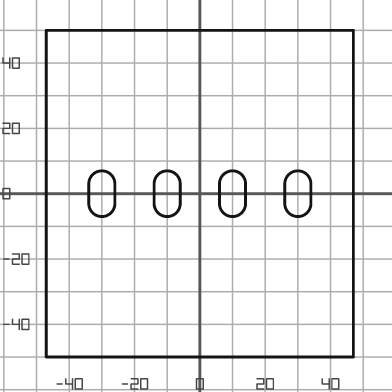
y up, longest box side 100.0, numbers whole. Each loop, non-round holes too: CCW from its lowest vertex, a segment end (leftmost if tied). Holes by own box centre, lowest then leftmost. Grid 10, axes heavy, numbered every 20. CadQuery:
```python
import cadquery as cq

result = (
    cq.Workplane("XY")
    .moveTo(-47.0, -50.0)
    .lineTo(47.0, -50.0)
    .lineTo(47.0, 50.0)
    .lineTo(-47.0, 50.0)
    .close()
    .moveTo(-34.0, -3.0)
    .threePointArc((-30.0, -7.0), (-26.0, -3.0))
    .lineTo(-26.0, 3.0)
    .threePointArc((-30.0, 7.0), (-34.0, 3.0))
    .close()
    .moveTo(-14.0, -3.0)
    .threePointArc((-10.0, -7.0), (-6.0, -3.0))
    .lineTo(-6.0, 3.0)
    .threePointArc((-10.0, 7.0), (-14.0, 3.0))
    .close()
    .moveTo(6.0, -3.0)
    .threePointArc((10.0, -7.0), (14.0, -3.0))
    .lineTo(14.0, 3.0)
    .threePointArc((10.0, 7.0), (6.0, 3.0))
    .close()
    .moveTo(26.0, -3.0)
    .threePointArc((30.0, -7.0), (34.0, -3.0))
    .lineTo(34.0, 3.0)
    .threePointArc((30.0, 7.0), (26.0, 3.0))
    .close()
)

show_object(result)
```